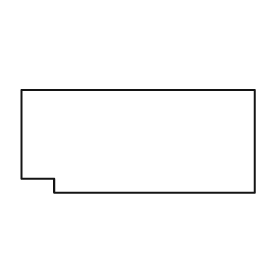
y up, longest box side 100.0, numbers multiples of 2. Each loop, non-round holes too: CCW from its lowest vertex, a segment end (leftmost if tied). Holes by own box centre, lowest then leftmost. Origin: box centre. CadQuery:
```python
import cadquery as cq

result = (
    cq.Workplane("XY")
    .moveTo(-36.0, -22.0)
    .lineTo(50.0, -22.0)
    .lineTo(50.0, 22.0)
    .lineTo(-50.0, 22.0)
    .lineTo(-50.0, -16.0)
    .lineTo(-36.0, -16.0)
    .close()
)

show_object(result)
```